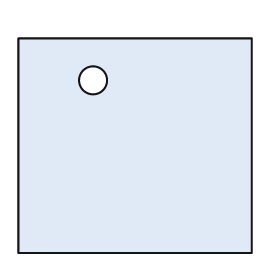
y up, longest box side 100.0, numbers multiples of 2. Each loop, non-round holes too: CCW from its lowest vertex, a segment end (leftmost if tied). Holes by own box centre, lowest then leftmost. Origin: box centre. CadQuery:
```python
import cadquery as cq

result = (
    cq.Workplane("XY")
    .moveTo(-50.0, -46.0)
    .lineTo(50.0, -46.0)
    .lineTo(50.0, 46.0)
    .lineTo(-50.0, 46.0)
    .close()
    .moveTo(-18.0, 28.0)
    .circle(6.0)
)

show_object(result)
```